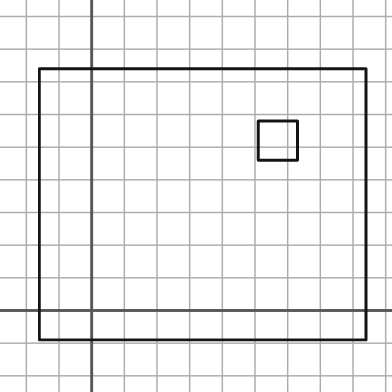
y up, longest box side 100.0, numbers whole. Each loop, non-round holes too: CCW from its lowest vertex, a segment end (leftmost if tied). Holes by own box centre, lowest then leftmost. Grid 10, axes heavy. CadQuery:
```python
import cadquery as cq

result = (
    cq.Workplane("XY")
    .moveTo(-16.0, -9.0)
    .lineTo(84.0, -9.0)
    .lineTo(84.0, 74.0)
    .lineTo(-16.0, 74.0)
    .close()
    .moveTo(51.0, 46.0)
    .lineTo(63.0, 46.0)
    .lineTo(63.0, 58.0)
    .lineTo(51.0, 58.0)
    .close()
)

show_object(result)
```